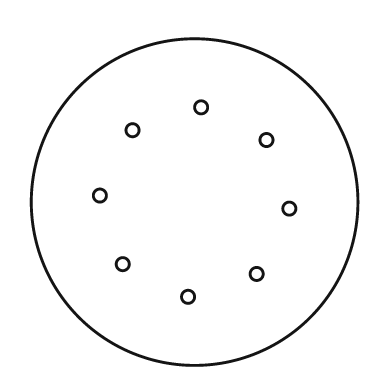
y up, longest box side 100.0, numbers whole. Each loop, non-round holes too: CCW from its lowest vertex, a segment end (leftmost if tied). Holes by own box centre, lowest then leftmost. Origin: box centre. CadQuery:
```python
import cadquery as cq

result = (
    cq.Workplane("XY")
    .moveTo(0.0, 0.0)
    .circle(50.0)
    .moveTo(-2.0, -29.0)
    .circle(2.0)
    .moveTo(19.0, -22.0)
    .circle(2.0)
    .moveTo(-22.0, -19.0)
    .circle(2.0)
    .moveTo(29.0, -2.0)
    .circle(2.0)
    .moveTo(-29.0, 2.0)
    .circle(2.0)
    .moveTo(22.0, 19.0)
    .circle(2.0)
    .moveTo(-19.0, 22.0)
    .circle(2.0)
    .moveTo(2.0, 29.0)
    .circle(2.0)
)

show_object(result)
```